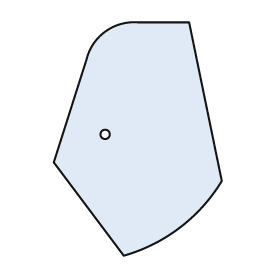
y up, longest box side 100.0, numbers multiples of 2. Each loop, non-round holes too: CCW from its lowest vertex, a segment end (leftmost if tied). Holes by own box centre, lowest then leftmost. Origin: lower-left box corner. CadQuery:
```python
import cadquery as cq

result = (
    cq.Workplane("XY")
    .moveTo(30.0, 0.0)
    .threePointArc((54.0, 12.0), (72.0, 32.0))
    .lineTo(58.0, 100.0)
    .lineTo(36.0, 100.0)
    .threePointArc((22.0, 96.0), (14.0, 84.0))
    .lineTo(0.0, 40.0)
    .close()
    .moveTo(22.0, 52.0)
    .circle(2.0)
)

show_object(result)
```